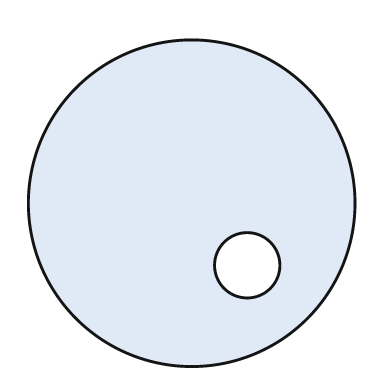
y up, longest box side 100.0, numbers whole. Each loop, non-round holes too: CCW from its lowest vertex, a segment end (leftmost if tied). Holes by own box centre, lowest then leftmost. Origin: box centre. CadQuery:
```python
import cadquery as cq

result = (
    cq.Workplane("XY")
    .moveTo(0.0, 0.0)
    .circle(50.0)
    .moveTo(17.0, -19.0)
    .circle(10.0)
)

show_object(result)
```